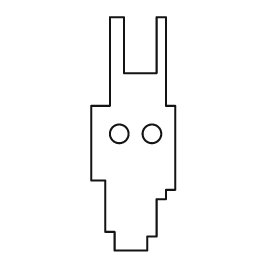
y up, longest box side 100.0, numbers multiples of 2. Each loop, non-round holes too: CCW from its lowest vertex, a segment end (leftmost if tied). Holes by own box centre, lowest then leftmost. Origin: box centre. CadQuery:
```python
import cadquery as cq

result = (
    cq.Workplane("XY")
    .moveTo(-8.0, -50.0)
    .lineTo(6.0, -50.0)
    .lineTo(6.0, -44.0)
    .lineTo(10.0, -44.0)
    .lineTo(10.0, -28.0)
    .lineTo(14.0, -28.0)
    .lineTo(14.0, -24.0)
    .lineTo(18.0, -24.0)
    .lineTo(18.0, 12.0)
    .lineTo(14.0, 12.0)
    .lineTo(14.0, 50.0)
    .lineTo(10.0, 50.0)
    .lineTo(10.0, 26.0)
    .lineTo(-4.0, 26.0)
    .lineTo(-4.0, 50.0)
    .lineTo(-10.0, 50.0)
    .lineTo(-10.0, 12.0)
    .lineTo(-18.0, 12.0)
    .lineTo(-18.0, -20.0)
    .lineTo(-12.0, -20.0)
    .lineTo(-12.0, -42.0)
    .lineTo(-8.0, -42.0)
    .close()
    .moveTo(-6.0, 0.0)
    .circle(4.0)
    .moveTo(8.0, 0.0)
    .circle(4.0)
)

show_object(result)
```